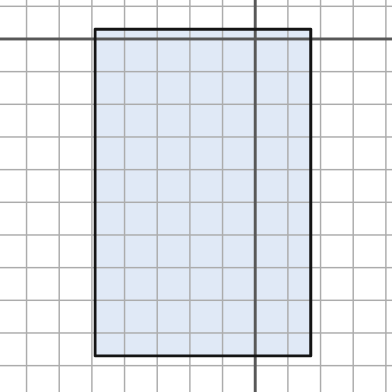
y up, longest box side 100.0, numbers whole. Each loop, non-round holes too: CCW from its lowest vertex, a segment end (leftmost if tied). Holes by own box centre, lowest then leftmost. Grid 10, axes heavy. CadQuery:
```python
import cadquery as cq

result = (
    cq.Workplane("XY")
    .moveTo(-49.0, -97.0)
    .lineTo(17.0, -97.0)
    .lineTo(17.0, 3.0)
    .lineTo(-49.0, 3.0)
    .close()
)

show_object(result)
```